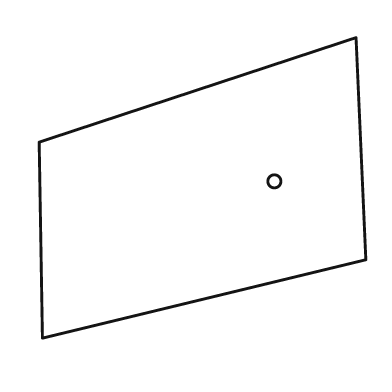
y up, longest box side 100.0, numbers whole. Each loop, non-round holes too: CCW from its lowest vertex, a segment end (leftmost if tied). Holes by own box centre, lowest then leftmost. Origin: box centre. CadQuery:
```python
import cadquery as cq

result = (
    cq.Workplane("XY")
    .moveTo(-49.0, -46.0)
    .lineTo(50.0, -22.0)
    .lineTo(47.0, 46.0)
    .lineTo(-50.0, 14.0)
    .close()
    .moveTo(22.0, 2.0)
    .circle(2.0)
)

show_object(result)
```